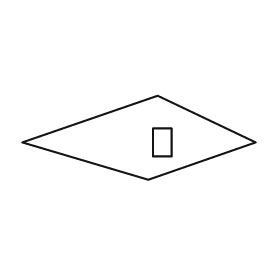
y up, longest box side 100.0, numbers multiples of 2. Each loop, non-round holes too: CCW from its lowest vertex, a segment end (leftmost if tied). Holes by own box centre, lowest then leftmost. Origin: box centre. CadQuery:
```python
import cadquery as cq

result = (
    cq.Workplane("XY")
    .moveTo(4.0, -18.0)
    .lineTo(50.0, -2.0)
    .lineTo(8.0, 18.0)
    .lineTo(-50.0, -2.0)
    .close()
    .moveTo(6.0, -8.0)
    .lineTo(14.0, -8.0)
    .lineTo(14.0, 4.0)
    .lineTo(6.0, 4.0)
    .close()
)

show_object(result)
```